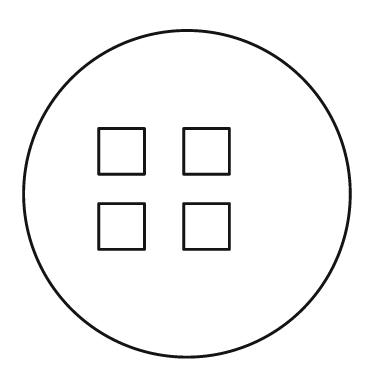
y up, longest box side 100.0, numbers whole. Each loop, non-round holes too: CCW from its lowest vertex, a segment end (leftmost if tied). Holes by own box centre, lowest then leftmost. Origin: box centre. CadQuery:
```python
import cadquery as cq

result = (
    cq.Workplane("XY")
    .moveTo(0.0, 0.0)
    .circle(50.0)
    .moveTo(-27.0, -17.0)
    .lineTo(-13.0, -17.0)
    .lineTo(-13.0, -3.0)
    .lineTo(-27.0, -3.0)
    .close()
    .moveTo(-1.0, -17.0)
    .lineTo(13.0, -17.0)
    .lineTo(13.0, -3.0)
    .lineTo(-1.0, -3.0)
    .close()
    .moveTo(-27.0, 6.0)
    .lineTo(-13.0, 6.0)
    .lineTo(-13.0, 20.0)
    .lineTo(-27.0, 20.0)
    .close()
    .moveTo(-1.0, 6.0)
    .lineTo(13.0, 6.0)
    .lineTo(13.0, 20.0)
    .lineTo(-1.0, 20.0)
    .close()
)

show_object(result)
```